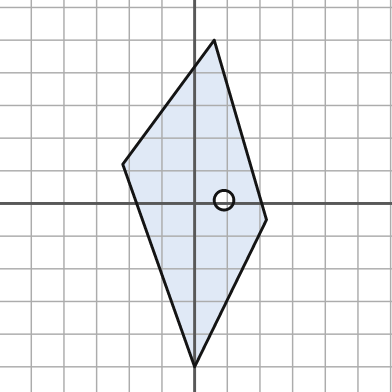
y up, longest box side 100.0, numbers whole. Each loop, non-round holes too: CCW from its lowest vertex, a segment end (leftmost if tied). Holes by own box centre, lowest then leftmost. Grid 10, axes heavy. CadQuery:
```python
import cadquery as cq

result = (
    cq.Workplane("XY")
    .moveTo(0.0, -50.0)
    .lineTo(22.0, -5.0)
    .lineTo(6.0, 50.0)
    .lineTo(-22.0, 12.0)
    .close()
    .moveTo(9.0, 1.0)
    .circle(3.0)
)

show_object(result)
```